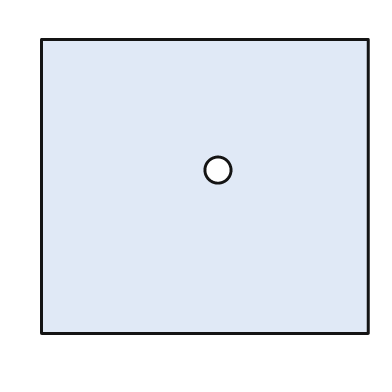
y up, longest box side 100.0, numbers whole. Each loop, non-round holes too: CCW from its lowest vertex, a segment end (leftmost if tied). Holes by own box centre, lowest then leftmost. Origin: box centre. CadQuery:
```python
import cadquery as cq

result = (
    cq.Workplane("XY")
    .moveTo(-50.0, -45.0)
    .lineTo(50.0, -45.0)
    .lineTo(50.0, 45.0)
    .lineTo(-50.0, 45.0)
    .close()
    .moveTo(4.0, 5.0)
    .circle(4.0)
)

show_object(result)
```